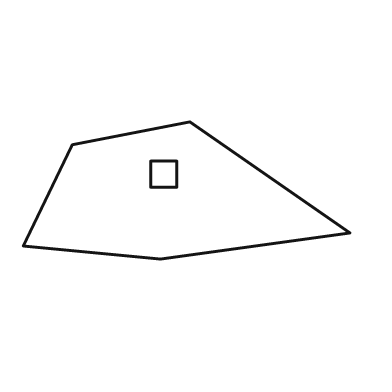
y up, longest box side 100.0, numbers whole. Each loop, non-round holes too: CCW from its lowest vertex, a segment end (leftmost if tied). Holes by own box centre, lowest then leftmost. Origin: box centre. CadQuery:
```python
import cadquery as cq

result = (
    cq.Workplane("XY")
    .moveTo(-8.0, -21.0)
    .lineTo(50.0, -13.0)
    .lineTo(1.0, 21.0)
    .lineTo(-35.0, 14.0)
    .lineTo(-50.0, -17.0)
    .close()
    .moveTo(-11.0, 1.0)
    .lineTo(-3.0, 1.0)
    .lineTo(-3.0, 9.0)
    .lineTo(-11.0, 9.0)
    .close()
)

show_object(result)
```